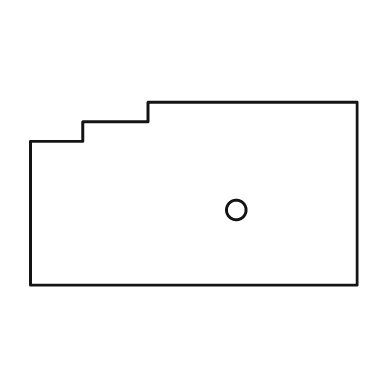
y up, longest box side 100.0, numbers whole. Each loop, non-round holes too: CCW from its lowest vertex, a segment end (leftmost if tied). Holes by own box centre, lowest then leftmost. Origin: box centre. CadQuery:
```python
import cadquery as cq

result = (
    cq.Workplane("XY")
    .moveTo(-50.0, -28.0)
    .lineTo(50.0, -28.0)
    .lineTo(50.0, 28.0)
    .lineTo(-14.0, 28.0)
    .lineTo(-14.0, 22.0)
    .lineTo(-34.0, 22.0)
    .lineTo(-34.0, 16.0)
    .lineTo(-50.0, 16.0)
    .close()
    .moveTo(13.0, -5.0)
    .circle(3.0)
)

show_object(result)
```